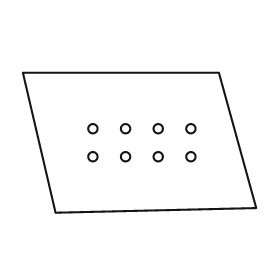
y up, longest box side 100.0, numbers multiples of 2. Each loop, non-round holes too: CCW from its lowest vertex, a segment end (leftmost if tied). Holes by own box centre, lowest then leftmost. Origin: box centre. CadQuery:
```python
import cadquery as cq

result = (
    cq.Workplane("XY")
    .moveTo(-36.0, -30.0)
    .lineTo(50.0, -28.0)
    .lineTo(34.0, 30.0)
    .lineTo(-50.0, 30.0)
    .close()
    .moveTo(-20.0, -6.0)
    .circle(2.0)
    .moveTo(-6.0, -6.0)
    .circle(2.0)
    .moveTo(8.0, -6.0)
    .circle(2.0)
    .moveTo(22.0, -6.0)
    .circle(2.0)
    .moveTo(-20.0, 6.0)
    .circle(2.0)
    .moveTo(-6.0, 6.0)
    .circle(2.0)
    .moveTo(8.0, 6.0)
    .circle(2.0)
    .moveTo(22.0, 6.0)
    .circle(2.0)
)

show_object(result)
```